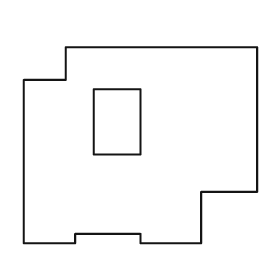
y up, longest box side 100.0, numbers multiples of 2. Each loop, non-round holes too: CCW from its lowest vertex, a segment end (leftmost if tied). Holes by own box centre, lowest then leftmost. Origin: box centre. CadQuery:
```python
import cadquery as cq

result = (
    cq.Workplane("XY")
    .moveTo(-50.0, -42.0)
    .lineTo(-28.0, -42.0)
    .lineTo(-28.0, -38.0)
    .lineTo(0.0, -38.0)
    .lineTo(0.0, -42.0)
    .lineTo(26.0, -42.0)
    .lineTo(26.0, -20.0)
    .lineTo(50.0, -20.0)
    .lineTo(50.0, 42.0)
    .lineTo(-32.0, 42.0)
    .lineTo(-32.0, 28.0)
    .lineTo(-50.0, 28.0)
    .close()
    .moveTo(-20.0, -4.0)
    .lineTo(0.0, -4.0)
    .lineTo(0.0, 24.0)
    .lineTo(-20.0, 24.0)
    .close()
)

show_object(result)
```